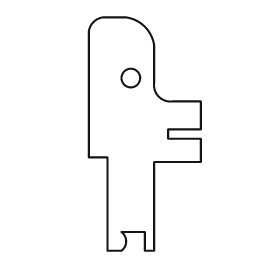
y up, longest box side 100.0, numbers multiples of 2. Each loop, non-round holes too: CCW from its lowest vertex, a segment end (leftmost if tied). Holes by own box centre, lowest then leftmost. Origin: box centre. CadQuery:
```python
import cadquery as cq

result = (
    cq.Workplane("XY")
    .moveTo(-16.0, -50.0)
    .lineTo(-10.0, -50.0)
    .threePointArc((-8.0, -46.0), (-10.0, -42.0))
    .lineTo(0.0, -42.0)
    .lineTo(0.0, -50.0)
    .lineTo(4.0, -50.0)
    .lineTo(4.0, -12.0)
    .lineTo(24.0, -12.0)
    .lineTo(24.0, -2.0)
    .lineTo(10.0, -2.0)
    .lineTo(10.0, 2.0)
    .lineTo(24.0, 2.0)
    .lineTo(24.0, 14.0)
    .lineTo(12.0, 14.0)
    .threePointArc((6.0, 16.0), (4.0, 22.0))
    .lineTo(4.0, 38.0)
    .threePointArc((0.0, 46.0), (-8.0, 50.0))
    .lineTo(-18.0, 50.0)
    .threePointArc((-22.0, 48.0), (-24.0, 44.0))
    .lineTo(-24.0, -10.0)
    .lineTo(-16.0, -10.0)
    .close()
    .moveTo(-6.0, 24.0)
    .circle(4.0)
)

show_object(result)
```